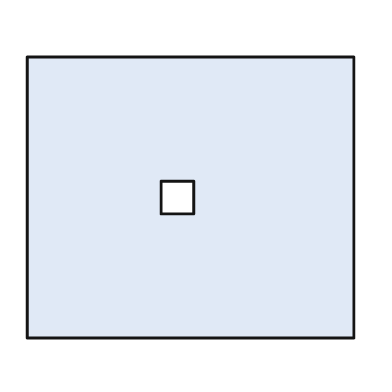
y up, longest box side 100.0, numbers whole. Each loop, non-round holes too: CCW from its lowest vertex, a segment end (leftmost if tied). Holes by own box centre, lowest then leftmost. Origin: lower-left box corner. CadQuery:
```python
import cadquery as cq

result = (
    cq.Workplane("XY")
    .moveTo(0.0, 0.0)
    .lineTo(100.0, 0.0)
    .lineTo(100.0, 86.0)
    .lineTo(0.0, 86.0)
    .close()
    .moveTo(41.0, 38.0)
    .lineTo(51.0, 38.0)
    .lineTo(51.0, 48.0)
    .lineTo(41.0, 48.0)
    .close()
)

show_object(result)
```